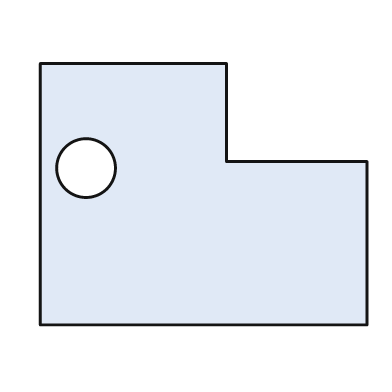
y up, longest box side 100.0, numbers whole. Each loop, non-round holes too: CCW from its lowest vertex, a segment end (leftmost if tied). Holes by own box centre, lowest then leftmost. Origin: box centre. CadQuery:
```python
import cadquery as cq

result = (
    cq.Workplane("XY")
    .moveTo(-50.0, -40.0)
    .lineTo(50.0, -40.0)
    .lineTo(50.0, 10.0)
    .lineTo(7.0, 10.0)
    .lineTo(7.0, 40.0)
    .lineTo(-50.0, 40.0)
    .close()
    .moveTo(-36.0, 8.0)
    .circle(9.0)
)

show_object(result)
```